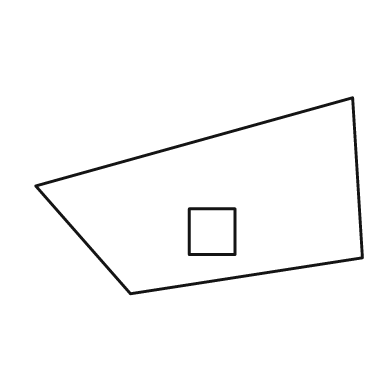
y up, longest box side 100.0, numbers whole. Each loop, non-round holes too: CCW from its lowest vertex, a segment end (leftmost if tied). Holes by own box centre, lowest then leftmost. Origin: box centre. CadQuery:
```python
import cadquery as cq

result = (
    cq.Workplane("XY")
    .moveTo(-21.0, -30.0)
    .lineTo(50.0, -19.0)
    .lineTo(47.0, 30.0)
    .lineTo(-50.0, 3.0)
    .close()
    .moveTo(-3.0, -18.0)
    .lineTo(11.0, -18.0)
    .lineTo(11.0, -4.0)
    .lineTo(-3.0, -4.0)
    .close()
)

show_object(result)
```